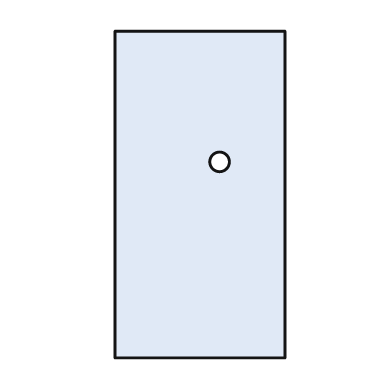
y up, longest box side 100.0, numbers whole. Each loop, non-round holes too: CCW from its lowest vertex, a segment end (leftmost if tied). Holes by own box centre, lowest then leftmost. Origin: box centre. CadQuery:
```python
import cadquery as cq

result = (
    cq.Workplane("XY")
    .moveTo(-26.0, -50.0)
    .lineTo(26.0, -50.0)
    .lineTo(26.0, 50.0)
    .lineTo(-26.0, 50.0)
    .close()
    .moveTo(6.0, 10.0)
    .circle(3.0)
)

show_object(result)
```